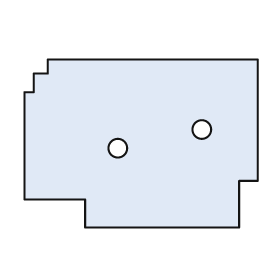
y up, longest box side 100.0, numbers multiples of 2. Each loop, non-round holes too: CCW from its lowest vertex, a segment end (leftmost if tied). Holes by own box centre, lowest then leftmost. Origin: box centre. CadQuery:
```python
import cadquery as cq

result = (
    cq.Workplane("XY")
    .moveTo(-24.0, -36.0)
    .lineTo(42.0, -36.0)
    .lineTo(42.0, -16.0)
    .lineTo(50.0, -16.0)
    .lineTo(50.0, 36.0)
    .lineTo(-40.0, 36.0)
    .lineTo(-40.0, 30.0)
    .lineTo(-46.0, 30.0)
    .lineTo(-46.0, 22.0)
    .lineTo(-50.0, 22.0)
    .lineTo(-50.0, -24.0)
    .lineTo(-24.0, -24.0)
    .close()
    .moveTo(-10.0, -2.0)
    .circle(4.0)
    .moveTo(26.0, 6.0)
    .circle(4.0)
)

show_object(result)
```